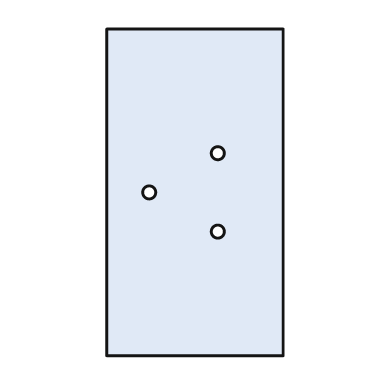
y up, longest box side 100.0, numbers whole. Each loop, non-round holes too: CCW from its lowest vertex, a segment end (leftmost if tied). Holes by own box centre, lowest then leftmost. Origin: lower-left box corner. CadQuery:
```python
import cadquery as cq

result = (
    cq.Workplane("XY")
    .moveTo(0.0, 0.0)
    .lineTo(54.0, 0.0)
    .lineTo(54.0, 100.0)
    .lineTo(0.0, 100.0)
    .close()
    .moveTo(34.0, 38.0)
    .circle(2.0)
    .moveTo(13.0, 50.0)
    .circle(2.0)
    .moveTo(34.0, 62.0)
    .circle(2.0)
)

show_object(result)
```